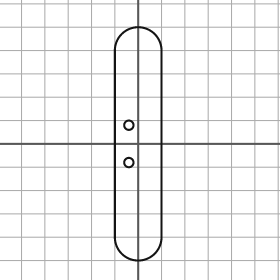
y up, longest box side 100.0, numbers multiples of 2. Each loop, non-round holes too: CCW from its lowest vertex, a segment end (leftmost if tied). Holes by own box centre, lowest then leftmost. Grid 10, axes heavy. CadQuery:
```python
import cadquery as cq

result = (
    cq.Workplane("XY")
    .moveTo(-10.0, -40.0)
    .threePointArc((0.0, -50.0), (10.0, -40.0))
    .lineTo(10.0, 40.0)
    .threePointArc((0.0, 50.0), (-10.0, 40.0))
    .close()
    .moveTo(-4.0, -8.0)
    .circle(2.0)
    .moveTo(-4.0, 8.0)
    .circle(2.0)
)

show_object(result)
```